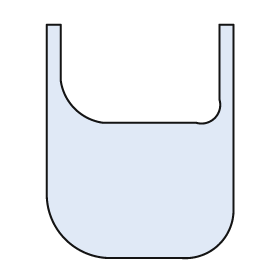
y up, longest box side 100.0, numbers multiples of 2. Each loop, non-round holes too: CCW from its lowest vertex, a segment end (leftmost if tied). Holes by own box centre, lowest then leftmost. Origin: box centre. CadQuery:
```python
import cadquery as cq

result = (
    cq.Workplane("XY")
    .moveTo(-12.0, -50.0)
    .lineTo(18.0, -50.0)
    .threePointArc((34.0, -44.0), (40.0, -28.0))
    .lineTo(40.0, 50.0)
    .lineTo(34.0, 50.0)
    .lineTo(34.0, 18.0)
    .threePointArc((32.0, 10.0), (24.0, 8.0))
    .lineTo(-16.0, 8.0)
    .threePointArc((-28.0, 14.0), (-34.0, 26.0))
    .lineTo(-34.0, 50.0)
    .lineTo(-40.0, 50.0)
    .lineTo(-40.0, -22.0)
    .threePointArc((-32.0, -42.0), (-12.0, -50.0))
    .close()
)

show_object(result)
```